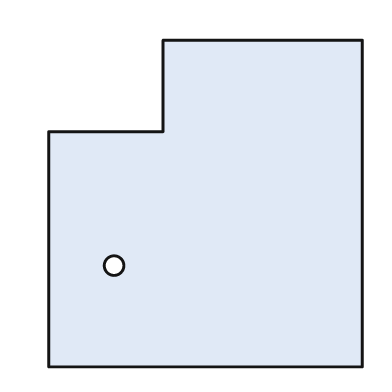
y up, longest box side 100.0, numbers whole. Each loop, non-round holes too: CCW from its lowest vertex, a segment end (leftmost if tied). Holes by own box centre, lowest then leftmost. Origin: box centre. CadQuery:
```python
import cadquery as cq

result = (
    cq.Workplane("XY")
    .moveTo(-48.0, -50.0)
    .lineTo(48.0, -50.0)
    .lineTo(48.0, 50.0)
    .lineTo(-13.0, 50.0)
    .lineTo(-13.0, 22.0)
    .lineTo(-48.0, 22.0)
    .close()
    .moveTo(-28.0, -19.0)
    .circle(3.0)
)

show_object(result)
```